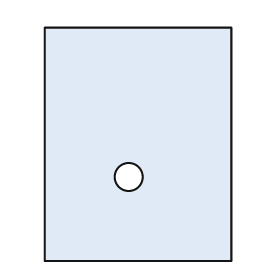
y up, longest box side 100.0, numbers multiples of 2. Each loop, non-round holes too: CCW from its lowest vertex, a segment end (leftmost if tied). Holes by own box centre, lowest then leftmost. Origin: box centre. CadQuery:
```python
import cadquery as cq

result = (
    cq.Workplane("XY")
    .moveTo(-40.0, -50.0)
    .lineTo(40.0, -50.0)
    .lineTo(40.0, 50.0)
    .lineTo(-40.0, 50.0)
    .close()
    .moveTo(-4.0, -14.0)
    .circle(6.0)
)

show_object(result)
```